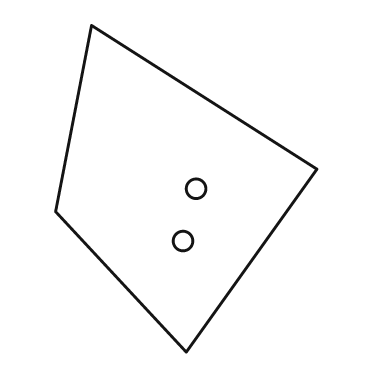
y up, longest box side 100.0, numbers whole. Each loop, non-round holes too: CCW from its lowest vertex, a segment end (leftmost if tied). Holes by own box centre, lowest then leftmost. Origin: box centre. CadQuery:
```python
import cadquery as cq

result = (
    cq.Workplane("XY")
    .moveTo(0.0, -50.0)
    .lineTo(40.0, 6.0)
    .lineTo(-29.0, 50.0)
    .lineTo(-40.0, -7.0)
    .close()
    .moveTo(-1.0, -16.0)
    .circle(3.0)
    .moveTo(3.0, 0.0)
    .circle(3.0)
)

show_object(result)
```